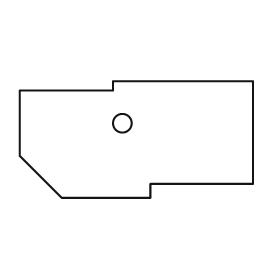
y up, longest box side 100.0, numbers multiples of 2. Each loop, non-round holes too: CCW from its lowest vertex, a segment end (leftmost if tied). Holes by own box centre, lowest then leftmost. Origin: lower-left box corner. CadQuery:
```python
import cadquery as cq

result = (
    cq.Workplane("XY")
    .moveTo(18.0, 0.0)
    .lineTo(56.0, 0.0)
    .lineTo(56.0, 6.0)
    .lineTo(100.0, 6.0)
    .lineTo(100.0, 50.0)
    .lineTo(40.0, 50.0)
    .lineTo(40.0, 46.0)
    .lineTo(0.0, 46.0)
    .lineTo(0.0, 18.0)
    .close()
    .moveTo(44.0, 32.0)
    .circle(4.0)
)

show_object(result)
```